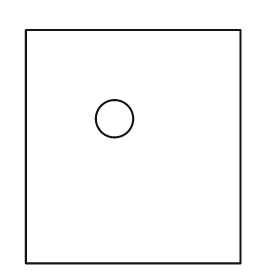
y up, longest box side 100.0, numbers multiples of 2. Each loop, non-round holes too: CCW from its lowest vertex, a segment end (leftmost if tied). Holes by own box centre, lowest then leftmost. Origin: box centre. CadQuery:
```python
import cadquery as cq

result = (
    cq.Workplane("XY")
    .moveTo(-46.0, -50.0)
    .lineTo(46.0, -50.0)
    .lineTo(46.0, 50.0)
    .lineTo(-46.0, 50.0)
    .close()
    .moveTo(-8.0, 12.0)
    .circle(8.0)
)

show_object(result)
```